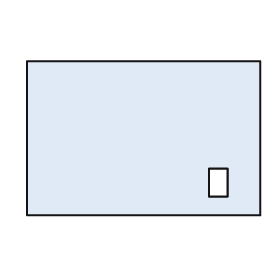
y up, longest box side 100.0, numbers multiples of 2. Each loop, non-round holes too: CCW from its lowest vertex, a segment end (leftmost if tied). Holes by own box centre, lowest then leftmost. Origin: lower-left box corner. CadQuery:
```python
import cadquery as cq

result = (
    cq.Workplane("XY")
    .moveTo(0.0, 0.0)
    .lineTo(100.0, 0.0)
    .lineTo(100.0, 66.0)
    .lineTo(0.0, 66.0)
    .close()
    .moveTo(78.0, 8.0)
    .lineTo(86.0, 8.0)
    .lineTo(86.0, 20.0)
    .lineTo(78.0, 20.0)
    .close()
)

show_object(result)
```